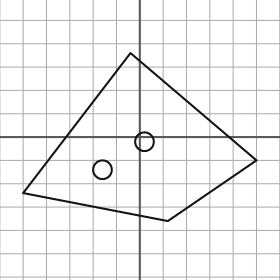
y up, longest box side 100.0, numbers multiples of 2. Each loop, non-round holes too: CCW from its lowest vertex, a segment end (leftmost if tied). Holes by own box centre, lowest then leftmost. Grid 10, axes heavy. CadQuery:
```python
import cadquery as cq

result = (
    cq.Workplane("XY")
    .moveTo(12.0, -36.0)
    .lineTo(50.0, -10.0)
    .lineTo(-4.0, 36.0)
    .lineTo(-50.0, -24.0)
    .close()
    .moveTo(-16.0, -14.0)
    .circle(4.0)
    .moveTo(2.0, -2.0)
    .circle(4.0)
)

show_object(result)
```